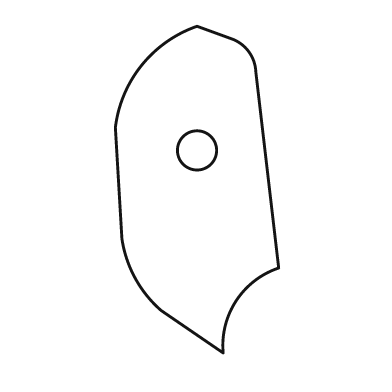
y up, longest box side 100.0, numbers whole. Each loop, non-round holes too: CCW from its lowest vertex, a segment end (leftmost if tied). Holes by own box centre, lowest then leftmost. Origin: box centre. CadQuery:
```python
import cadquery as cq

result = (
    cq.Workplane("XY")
    .moveTo(8.0, -50.0)
    .threePointArc((12.0, -34.0), (25.0, -24.0))
    .lineTo(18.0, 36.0)
    .threePointArc((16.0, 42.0), (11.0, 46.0))
    .lineTo(0.0, 50.0)
    .threePointArc((-17.0, 38.0), (-25.0, 19.0))
    .lineTo(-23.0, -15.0)
    .threePointArc((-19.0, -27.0), (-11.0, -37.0))
    .close()
    .moveTo(0.0, 12.0)
    .circle(6.0)
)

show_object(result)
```